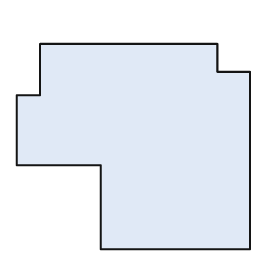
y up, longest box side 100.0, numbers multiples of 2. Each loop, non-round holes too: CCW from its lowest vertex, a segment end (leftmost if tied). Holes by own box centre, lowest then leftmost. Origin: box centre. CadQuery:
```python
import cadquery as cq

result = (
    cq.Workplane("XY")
    .moveTo(-14.0, -44.0)
    .lineTo(50.0, -44.0)
    .lineTo(50.0, 32.0)
    .lineTo(36.0, 32.0)
    .lineTo(36.0, 44.0)
    .lineTo(-40.0, 44.0)
    .lineTo(-40.0, 22.0)
    .lineTo(-50.0, 22.0)
    .lineTo(-50.0, -8.0)
    .lineTo(-14.0, -8.0)
    .close()
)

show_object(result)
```